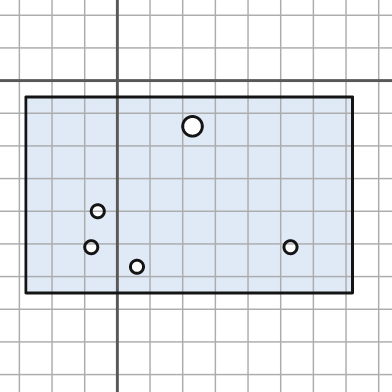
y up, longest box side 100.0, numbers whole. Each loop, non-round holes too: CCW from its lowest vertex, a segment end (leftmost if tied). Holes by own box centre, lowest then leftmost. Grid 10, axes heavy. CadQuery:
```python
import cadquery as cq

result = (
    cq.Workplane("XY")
    .moveTo(-28.0, -65.0)
    .lineTo(72.0, -65.0)
    .lineTo(72.0, -5.0)
    .lineTo(-28.0, -5.0)
    .close()
    .moveTo(6.0, -57.0)
    .circle(2.0)
    .moveTo(-8.0, -51.0)
    .circle(2.0)
    .moveTo(53.0, -51.0)
    .circle(2.0)
    .moveTo(-6.0, -40.0)
    .circle(2.0)
    .moveTo(23.0, -14.0)
    .circle(3.0)
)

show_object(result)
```